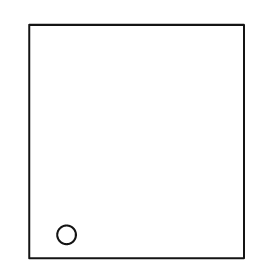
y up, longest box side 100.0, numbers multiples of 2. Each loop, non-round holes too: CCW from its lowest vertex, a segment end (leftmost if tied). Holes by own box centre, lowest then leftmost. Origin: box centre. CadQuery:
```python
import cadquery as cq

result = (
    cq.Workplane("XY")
    .moveTo(-46.0, -50.0)
    .lineTo(46.0, -50.0)
    .lineTo(46.0, 50.0)
    .lineTo(-46.0, 50.0)
    .close()
    .moveTo(-30.0, -40.0)
    .circle(4.0)
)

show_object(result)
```